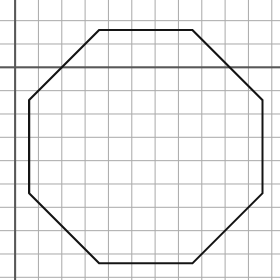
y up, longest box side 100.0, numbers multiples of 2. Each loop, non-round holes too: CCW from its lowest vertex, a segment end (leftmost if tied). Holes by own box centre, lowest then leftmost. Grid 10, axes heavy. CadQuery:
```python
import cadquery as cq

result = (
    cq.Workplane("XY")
    .moveTo(36.0, -84.0)
    .lineTo(76.0, -84.0)
    .lineTo(106.0, -54.0)
    .lineTo(106.0, -14.0)
    .lineTo(76.0, 16.0)
    .lineTo(36.0, 16.0)
    .lineTo(6.0, -14.0)
    .lineTo(6.0, -54.0)
    .close()
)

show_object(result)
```